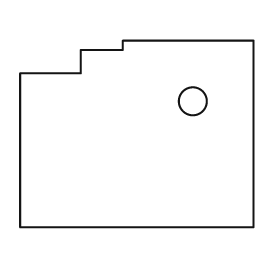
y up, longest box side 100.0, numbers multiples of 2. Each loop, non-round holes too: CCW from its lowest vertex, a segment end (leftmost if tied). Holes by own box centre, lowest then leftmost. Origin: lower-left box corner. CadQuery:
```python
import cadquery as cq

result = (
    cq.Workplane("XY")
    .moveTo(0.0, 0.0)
    .lineTo(100.0, 0.0)
    .lineTo(100.0, 80.0)
    .lineTo(44.0, 80.0)
    .lineTo(44.0, 76.0)
    .lineTo(26.0, 76.0)
    .lineTo(26.0, 66.0)
    .lineTo(0.0, 66.0)
    .close()
    .moveTo(74.0, 54.0)
    .circle(6.0)
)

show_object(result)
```